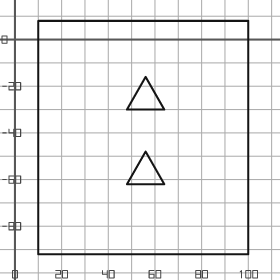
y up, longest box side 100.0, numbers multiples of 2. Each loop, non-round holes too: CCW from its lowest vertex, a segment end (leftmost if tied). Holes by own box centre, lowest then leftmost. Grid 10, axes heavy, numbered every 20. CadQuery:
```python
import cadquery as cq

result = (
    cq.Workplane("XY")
    .moveTo(10.0, -92.0)
    .lineTo(100.0, -92.0)
    .lineTo(100.0, 8.0)
    .lineTo(10.0, 8.0)
    .close()
    .moveTo(48.0, -62.0)
    .lineTo(64.0, -62.0)
    .lineTo(56.0, -48.0)
    .close()
    .moveTo(48.0, -30.0)
    .lineTo(64.0, -30.0)
    .lineTo(56.0, -16.0)
    .close()
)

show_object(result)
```